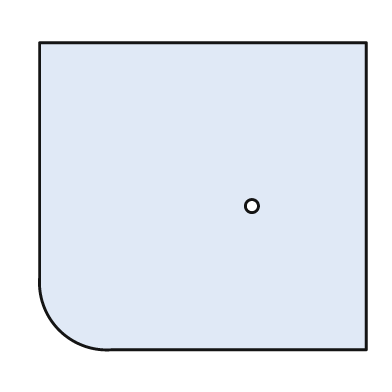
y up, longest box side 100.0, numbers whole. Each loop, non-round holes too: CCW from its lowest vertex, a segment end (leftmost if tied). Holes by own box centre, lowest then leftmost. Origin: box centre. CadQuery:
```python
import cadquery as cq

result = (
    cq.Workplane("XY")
    .moveTo(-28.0, -47.0)
    .lineTo(50.0, -47.0)
    .lineTo(50.0, 47.0)
    .lineTo(-50.0, 47.0)
    .lineTo(-50.0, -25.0)
    .threePointArc((-44.0, -41.0), (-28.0, -47.0))
    .close()
    .moveTo(15.0, -3.0)
    .circle(2.0)
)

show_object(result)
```